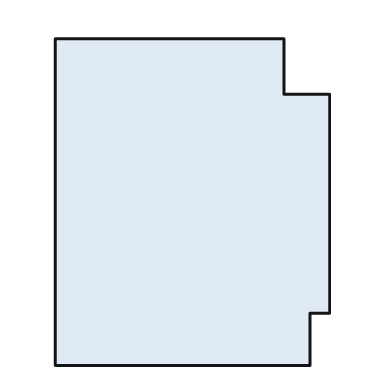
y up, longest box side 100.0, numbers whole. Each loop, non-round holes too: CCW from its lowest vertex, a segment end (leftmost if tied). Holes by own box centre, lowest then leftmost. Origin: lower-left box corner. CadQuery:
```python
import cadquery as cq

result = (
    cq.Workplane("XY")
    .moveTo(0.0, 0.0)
    .lineTo(78.0, 0.0)
    .lineTo(78.0, 16.0)
    .lineTo(84.0, 16.0)
    .lineTo(84.0, 83.0)
    .lineTo(70.0, 83.0)
    .lineTo(70.0, 100.0)
    .lineTo(0.0, 100.0)
    .close()
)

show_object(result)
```